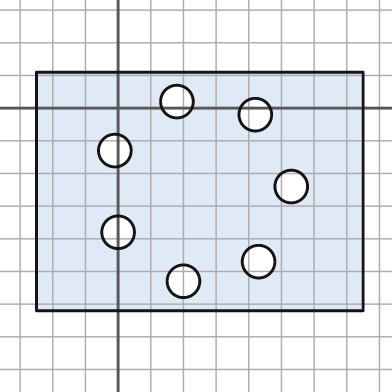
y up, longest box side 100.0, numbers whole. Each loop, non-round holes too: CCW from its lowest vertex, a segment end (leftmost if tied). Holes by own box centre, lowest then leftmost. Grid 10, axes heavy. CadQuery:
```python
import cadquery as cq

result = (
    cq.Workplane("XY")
    .moveTo(-25.0, -62.0)
    .lineTo(75.0, -62.0)
    .lineTo(75.0, 11.0)
    .lineTo(-25.0, 11.0)
    .close()
    .moveTo(20.0, -53.0)
    .circle(5.0)
    .moveTo(43.0, -47.0)
    .circle(5.0)
    .moveTo(0.0, -38.0)
    .circle(5.0)
    .moveTo(53.0, -24.0)
    .circle(5.0)
    .moveTo(-1.0, -13.0)
    .circle(5.0)
    .moveTo(42.0, -2.0)
    .circle(5.0)
    .moveTo(18.0, 2.0)
    .circle(5.0)
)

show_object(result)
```